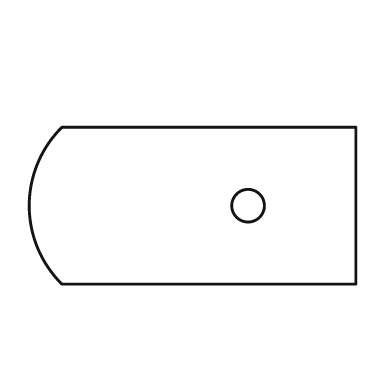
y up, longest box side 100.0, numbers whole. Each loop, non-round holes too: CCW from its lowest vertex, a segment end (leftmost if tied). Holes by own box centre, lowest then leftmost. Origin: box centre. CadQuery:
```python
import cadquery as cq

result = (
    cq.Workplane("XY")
    .moveTo(-40.0, -24.0)
    .lineTo(50.0, -24.0)
    .lineTo(50.0, 24.0)
    .lineTo(-40.0, 24.0)
    .threePointArc((-50.0, 0.0), (-40.0, -24.0))
    .close()
    .moveTo(17.0, 0.0)
    .circle(5.0)
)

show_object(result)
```